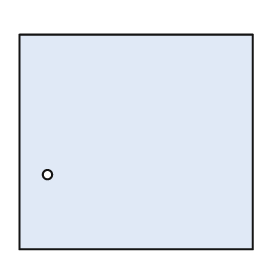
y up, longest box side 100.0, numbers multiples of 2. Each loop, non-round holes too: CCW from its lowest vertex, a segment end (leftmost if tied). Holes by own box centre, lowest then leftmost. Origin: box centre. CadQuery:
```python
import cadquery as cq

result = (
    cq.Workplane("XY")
    .moveTo(-50.0, -46.0)
    .lineTo(50.0, -46.0)
    .lineTo(50.0, 46.0)
    .lineTo(-50.0, 46.0)
    .close()
    .moveTo(-38.0, -14.0)
    .circle(2.0)
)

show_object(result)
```